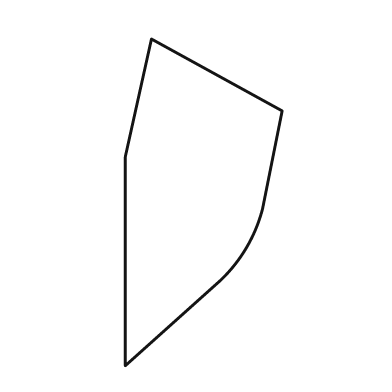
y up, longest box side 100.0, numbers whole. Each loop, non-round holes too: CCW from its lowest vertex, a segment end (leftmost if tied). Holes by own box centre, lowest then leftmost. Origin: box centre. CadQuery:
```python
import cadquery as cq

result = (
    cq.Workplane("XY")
    .moveTo(-24.0, -50.0)
    .lineTo(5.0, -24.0)
    .threePointArc((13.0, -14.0), (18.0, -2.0))
    .lineTo(24.0, 28.0)
    .lineTo(-16.0, 50.0)
    .lineTo(-24.0, 14.0)
    .close()
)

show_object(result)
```